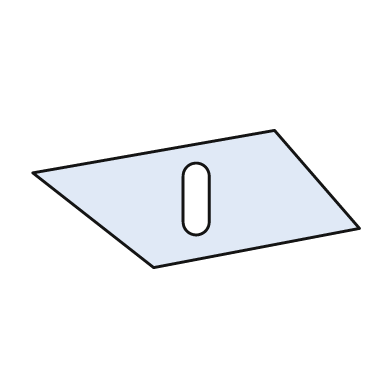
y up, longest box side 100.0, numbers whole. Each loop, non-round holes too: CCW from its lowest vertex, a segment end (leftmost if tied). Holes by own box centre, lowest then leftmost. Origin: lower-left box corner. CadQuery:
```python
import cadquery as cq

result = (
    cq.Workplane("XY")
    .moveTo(37.0, 0.0)
    .lineTo(100.0, 12.0)
    .lineTo(74.0, 42.0)
    .lineTo(0.0, 29.0)
    .close()
    .moveTo(46.0, 14.0)
    .threePointArc((50.0, 10.0), (54.0, 14.0))
    .lineTo(54.0, 28.0)
    .threePointArc((50.0, 32.0), (46.0, 28.0))
    .close()
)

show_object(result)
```